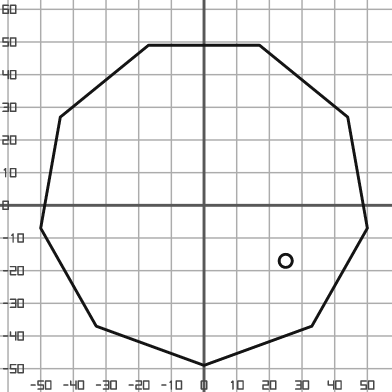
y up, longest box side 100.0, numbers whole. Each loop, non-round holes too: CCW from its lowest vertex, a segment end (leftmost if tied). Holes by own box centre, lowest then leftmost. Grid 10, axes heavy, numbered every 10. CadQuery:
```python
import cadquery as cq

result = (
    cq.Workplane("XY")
    .moveTo(0.0, -49.0)
    .lineTo(33.0, -37.0)
    .lineTo(50.0, -7.0)
    .lineTo(44.0, 27.0)
    .lineTo(17.0, 49.0)
    .lineTo(-17.0, 49.0)
    .lineTo(-44.0, 27.0)
    .lineTo(-50.0, -7.0)
    .lineTo(-33.0, -37.0)
    .close()
    .moveTo(25.0, -17.0)
    .circle(2.0)
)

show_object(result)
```